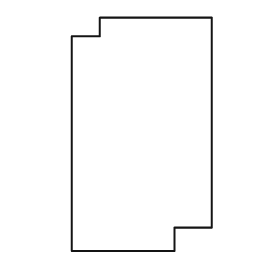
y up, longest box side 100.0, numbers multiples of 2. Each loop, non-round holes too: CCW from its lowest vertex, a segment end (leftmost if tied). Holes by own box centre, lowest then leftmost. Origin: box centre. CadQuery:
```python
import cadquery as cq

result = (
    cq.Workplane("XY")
    .moveTo(-30.0, -50.0)
    .lineTo(14.0, -50.0)
    .lineTo(14.0, -40.0)
    .lineTo(30.0, -40.0)
    .lineTo(30.0, 50.0)
    .lineTo(-18.0, 50.0)
    .lineTo(-18.0, 42.0)
    .lineTo(-30.0, 42.0)
    .close()
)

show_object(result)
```